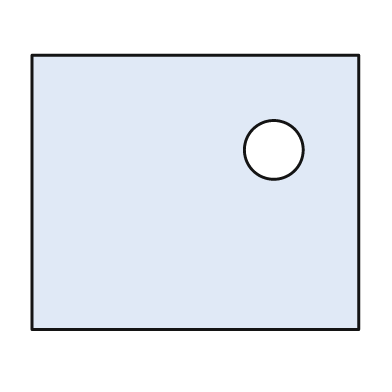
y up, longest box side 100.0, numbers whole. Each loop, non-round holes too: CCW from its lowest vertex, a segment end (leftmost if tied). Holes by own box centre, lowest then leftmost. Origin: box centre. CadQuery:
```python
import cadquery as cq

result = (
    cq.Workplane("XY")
    .moveTo(-50.0, -42.0)
    .lineTo(50.0, -42.0)
    .lineTo(50.0, 42.0)
    .lineTo(-50.0, 42.0)
    .close()
    .moveTo(24.0, 13.0)
    .circle(9.0)
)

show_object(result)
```